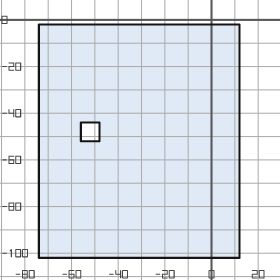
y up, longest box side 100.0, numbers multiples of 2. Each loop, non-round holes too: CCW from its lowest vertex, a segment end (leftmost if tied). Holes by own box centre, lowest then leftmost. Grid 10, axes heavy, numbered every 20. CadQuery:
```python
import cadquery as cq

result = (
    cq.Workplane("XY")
    .moveTo(-74.0, -102.0)
    .lineTo(12.0, -102.0)
    .lineTo(12.0, -2.0)
    .lineTo(-74.0, -2.0)
    .close()
    .moveTo(-56.0, -52.0)
    .lineTo(-48.0, -52.0)
    .lineTo(-48.0, -44.0)
    .lineTo(-56.0, -44.0)
    .close()
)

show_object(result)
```